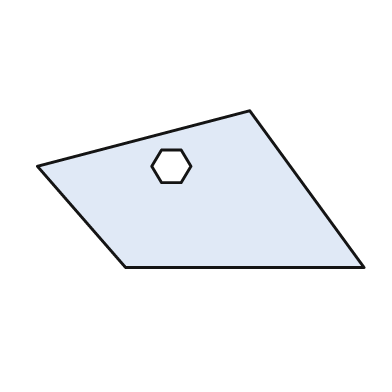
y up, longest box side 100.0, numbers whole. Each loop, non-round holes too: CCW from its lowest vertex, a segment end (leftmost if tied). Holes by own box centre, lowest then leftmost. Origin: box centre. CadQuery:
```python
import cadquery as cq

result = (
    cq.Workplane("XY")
    .moveTo(-23.0, -24.0)
    .lineTo(50.0, -24.0)
    .lineTo(15.0, 24.0)
    .lineTo(-50.0, 7.0)
    .close()
    .moveTo(-12.0, 2.0)
    .lineTo(-6.0, 2.0)
    .lineTo(-3.0, 7.0)
    .lineTo(-6.0, 12.0)
    .lineTo(-12.0, 12.0)
    .lineTo(-15.0, 7.0)
    .close()
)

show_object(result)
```